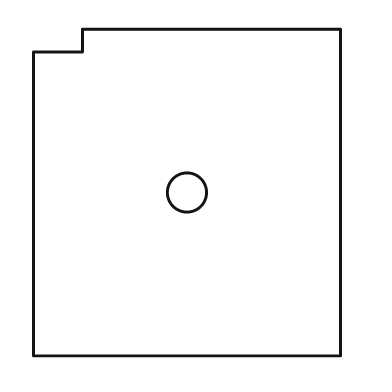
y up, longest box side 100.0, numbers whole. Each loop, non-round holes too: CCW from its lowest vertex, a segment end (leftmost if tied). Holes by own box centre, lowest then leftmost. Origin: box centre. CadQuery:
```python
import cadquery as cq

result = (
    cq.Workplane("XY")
    .moveTo(-47.0, -50.0)
    .lineTo(47.0, -50.0)
    .lineTo(47.0, 50.0)
    .lineTo(-32.0, 50.0)
    .lineTo(-32.0, 43.0)
    .lineTo(-47.0, 43.0)
    .close()
    .moveTo(0.0, 0.0)
    .circle(6.0)
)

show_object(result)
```